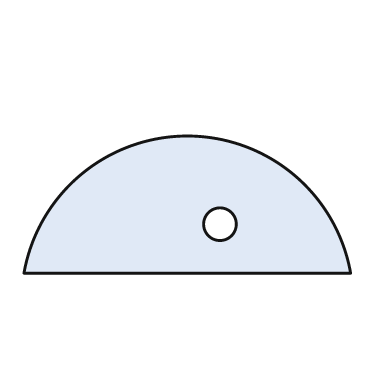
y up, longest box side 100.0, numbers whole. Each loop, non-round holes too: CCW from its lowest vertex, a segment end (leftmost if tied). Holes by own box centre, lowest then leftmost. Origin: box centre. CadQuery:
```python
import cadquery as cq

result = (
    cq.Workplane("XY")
    .moveTo(-50.0, -21.0)
    .lineTo(50.0, -21.0)
    .threePointArc((0.0, 21.0), (-50.0, -21.0))
    .close()
    .moveTo(10.0, -6.0)
    .circle(5.0)
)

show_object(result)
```